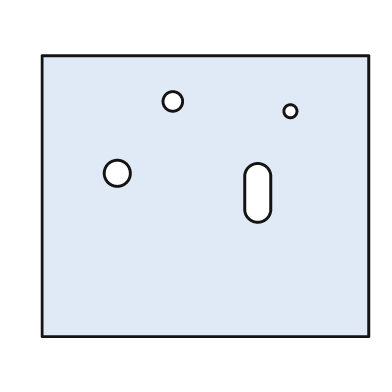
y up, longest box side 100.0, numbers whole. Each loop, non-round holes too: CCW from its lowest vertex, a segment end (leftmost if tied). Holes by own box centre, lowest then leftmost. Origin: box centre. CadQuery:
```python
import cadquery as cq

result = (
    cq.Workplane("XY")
    .moveTo(-50.0, -43.0)
    .lineTo(50.0, -43.0)
    .lineTo(50.0, 43.0)
    .lineTo(-50.0, 43.0)
    .close()
    .moveTo(12.0, -4.0)
    .threePointArc((16.0, -8.0), (20.0, -4.0))
    .lineTo(20.0, 6.0)
    .threePointArc((16.0, 10.0), (12.0, 6.0))
    .close()
    .moveTo(-27.0, 7.0)
    .circle(4.0)
    .moveTo(26.0, 26.0)
    .circle(2.0)
    .moveTo(-10.0, 29.0)
    .circle(3.0)
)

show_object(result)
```